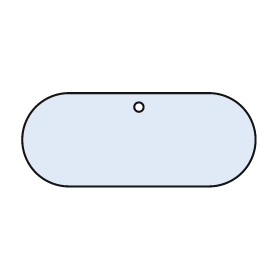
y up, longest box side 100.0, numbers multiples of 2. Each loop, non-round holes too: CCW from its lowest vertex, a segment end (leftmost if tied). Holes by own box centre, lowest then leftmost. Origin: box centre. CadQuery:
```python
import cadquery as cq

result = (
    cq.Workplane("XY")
    .moveTo(-30.0, -20.0)
    .lineTo(30.0, -20.0)
    .threePointArc((50.0, 0.0), (30.0, 20.0))
    .lineTo(-30.0, 20.0)
    .threePointArc((-50.0, 0.0), (-30.0, -20.0))
    .close()
    .moveTo(0.0, 14.0)
    .circle(2.0)
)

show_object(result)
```